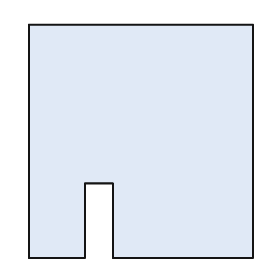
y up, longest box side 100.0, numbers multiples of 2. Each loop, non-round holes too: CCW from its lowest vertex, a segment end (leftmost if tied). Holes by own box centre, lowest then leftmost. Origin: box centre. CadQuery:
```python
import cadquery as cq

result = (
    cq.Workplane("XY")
    .moveTo(-48.0, -50.0)
    .lineTo(-24.0, -50.0)
    .lineTo(-24.0, -18.0)
    .lineTo(-12.0, -18.0)
    .lineTo(-12.0, -50.0)
    .lineTo(48.0, -50.0)
    .lineTo(48.0, 50.0)
    .lineTo(-48.0, 50.0)
    .close()
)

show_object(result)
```